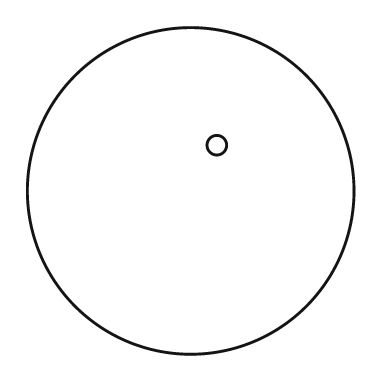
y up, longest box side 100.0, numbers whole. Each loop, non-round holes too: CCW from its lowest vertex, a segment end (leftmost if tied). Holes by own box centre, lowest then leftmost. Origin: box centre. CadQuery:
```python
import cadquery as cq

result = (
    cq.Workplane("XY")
    .moveTo(0.0, 0.0)
    .circle(50.0)
    .moveTo(8.0, 14.0)
    .circle(3.0)
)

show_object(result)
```